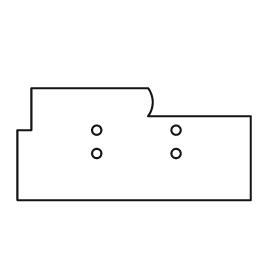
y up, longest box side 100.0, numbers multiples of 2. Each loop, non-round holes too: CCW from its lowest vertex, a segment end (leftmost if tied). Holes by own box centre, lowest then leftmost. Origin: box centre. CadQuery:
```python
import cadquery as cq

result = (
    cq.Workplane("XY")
    .moveTo(-50.0, -24.0)
    .lineTo(50.0, -24.0)
    .lineTo(50.0, 12.0)
    .lineTo(6.0, 12.0)
    .threePointArc((8.0, 18.0), (6.0, 24.0))
    .lineTo(-44.0, 24.0)
    .lineTo(-44.0, 6.0)
    .lineTo(-50.0, 6.0)
    .close()
    .moveTo(-16.0, -4.0)
    .circle(2.0)
    .moveTo(18.0, -4.0)
    .circle(2.0)
    .moveTo(-16.0, 6.0)
    .circle(2.0)
    .moveTo(18.0, 6.0)
    .circle(2.0)
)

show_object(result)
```